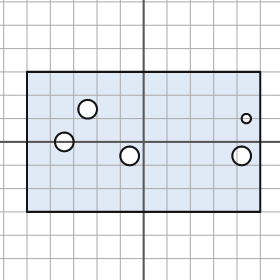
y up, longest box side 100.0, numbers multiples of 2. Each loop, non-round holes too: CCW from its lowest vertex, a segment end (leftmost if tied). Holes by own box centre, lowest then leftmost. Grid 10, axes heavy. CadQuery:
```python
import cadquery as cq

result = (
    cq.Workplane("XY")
    .moveTo(-50.0, -30.0)
    .lineTo(50.0, -30.0)
    .lineTo(50.0, 30.0)
    .lineTo(-50.0, 30.0)
    .close()
    .moveTo(-6.0, -6.0)
    .circle(4.0)
    .moveTo(42.0, -6.0)
    .circle(4.0)
    .moveTo(-34.0, 0.0)
    .circle(4.0)
    .moveTo(44.0, 10.0)
    .circle(2.0)
    .moveTo(-24.0, 14.0)
    .circle(4.0)
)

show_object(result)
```